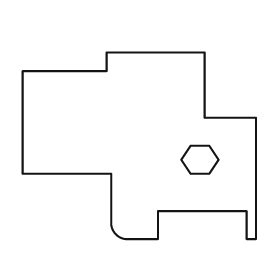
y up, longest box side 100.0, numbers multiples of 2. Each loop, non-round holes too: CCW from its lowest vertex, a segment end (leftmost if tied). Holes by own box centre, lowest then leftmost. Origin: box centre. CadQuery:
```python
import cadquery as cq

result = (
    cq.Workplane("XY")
    .moveTo(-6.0, -40.0)
    .lineTo(8.0, -40.0)
    .lineTo(8.0, -28.0)
    .lineTo(46.0, -28.0)
    .lineTo(46.0, -40.0)
    .lineTo(50.0, -40.0)
    .lineTo(50.0, 12.0)
    .lineTo(28.0, 12.0)
    .lineTo(28.0, 40.0)
    .lineTo(-14.0, 40.0)
    .lineTo(-14.0, 32.0)
    .lineTo(-50.0, 32.0)
    .lineTo(-50.0, -12.0)
    .lineTo(-12.0, -12.0)
    .lineTo(-12.0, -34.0)
    .threePointArc((-10.0, -38.0), (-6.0, -40.0))
    .close()
    .moveTo(22.0, -12.0)
    .lineTo(30.0, -12.0)
    .lineTo(34.0, -6.0)
    .lineTo(30.0, 0.0)
    .lineTo(22.0, 0.0)
    .lineTo(18.0, -6.0)
    .close()
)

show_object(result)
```